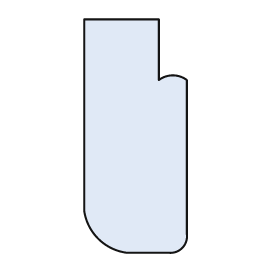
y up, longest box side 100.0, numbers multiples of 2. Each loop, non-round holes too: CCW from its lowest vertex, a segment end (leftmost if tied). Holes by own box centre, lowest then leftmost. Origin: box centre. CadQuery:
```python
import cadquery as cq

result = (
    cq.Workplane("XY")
    .moveTo(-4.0, -50.0)
    .lineTo(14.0, -50.0)
    .threePointArc((20.0, -48.0), (22.0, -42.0))
    .lineTo(22.0, 24.0)
    .threePointArc((16.0, 26.0), (10.0, 24.0))
    .lineTo(10.0, 50.0)
    .lineTo(-22.0, 50.0)
    .lineTo(-22.0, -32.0)
    .threePointArc((-16.0, -44.0), (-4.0, -50.0))
    .close()
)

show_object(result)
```